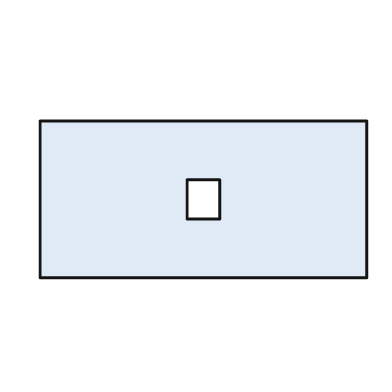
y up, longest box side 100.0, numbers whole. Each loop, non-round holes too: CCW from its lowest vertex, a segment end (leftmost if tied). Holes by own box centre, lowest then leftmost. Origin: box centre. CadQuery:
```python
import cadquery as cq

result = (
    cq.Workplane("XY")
    .moveTo(-50.0, -24.0)
    .lineTo(50.0, -24.0)
    .lineTo(50.0, 24.0)
    .lineTo(-50.0, 24.0)
    .close()
    .moveTo(-5.0, -6.0)
    .lineTo(5.0, -6.0)
    .lineTo(5.0, 6.0)
    .lineTo(-5.0, 6.0)
    .close()
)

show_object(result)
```